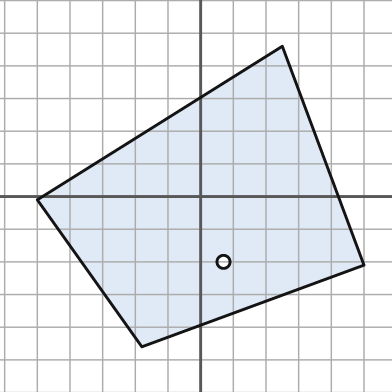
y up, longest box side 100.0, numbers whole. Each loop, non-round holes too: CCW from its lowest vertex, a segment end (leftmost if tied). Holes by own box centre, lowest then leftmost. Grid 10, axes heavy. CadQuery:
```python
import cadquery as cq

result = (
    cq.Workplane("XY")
    .moveTo(-18.0, -46.0)
    .lineTo(50.0, -21.0)
    .lineTo(25.0, 46.0)
    .lineTo(-50.0, -1.0)
    .close()
    .moveTo(7.0, -20.0)
    .circle(2.0)
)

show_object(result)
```